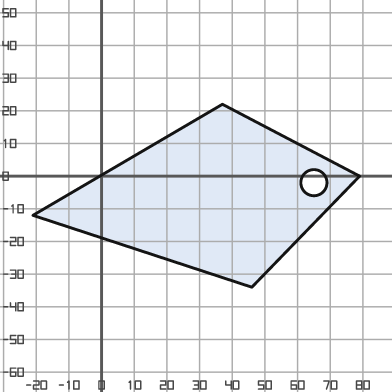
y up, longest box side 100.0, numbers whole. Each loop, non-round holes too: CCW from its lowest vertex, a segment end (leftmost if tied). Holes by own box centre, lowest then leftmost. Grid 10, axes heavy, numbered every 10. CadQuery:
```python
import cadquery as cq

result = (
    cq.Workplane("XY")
    .moveTo(46.0, -34.0)
    .lineTo(79.0, 0.0)
    .lineTo(37.0, 22.0)
    .lineTo(-21.0, -12.0)
    .close()
    .moveTo(65.0, -2.0)
    .circle(4.0)
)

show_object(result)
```